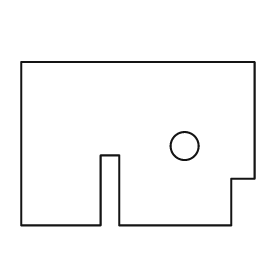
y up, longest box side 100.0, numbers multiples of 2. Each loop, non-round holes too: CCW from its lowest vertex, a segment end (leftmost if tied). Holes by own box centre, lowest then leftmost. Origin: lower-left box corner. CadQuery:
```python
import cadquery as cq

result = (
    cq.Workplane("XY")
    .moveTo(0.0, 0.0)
    .lineTo(34.0, 0.0)
    .lineTo(34.0, 30.0)
    .lineTo(42.0, 30.0)
    .lineTo(42.0, 0.0)
    .lineTo(90.0, 0.0)
    .lineTo(90.0, 20.0)
    .lineTo(100.0, 20.0)
    .lineTo(100.0, 70.0)
    .lineTo(0.0, 70.0)
    .close()
    .moveTo(70.0, 34.0)
    .circle(6.0)
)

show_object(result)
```